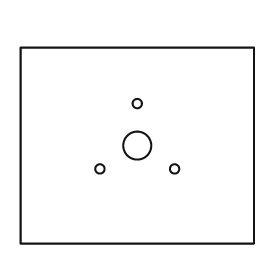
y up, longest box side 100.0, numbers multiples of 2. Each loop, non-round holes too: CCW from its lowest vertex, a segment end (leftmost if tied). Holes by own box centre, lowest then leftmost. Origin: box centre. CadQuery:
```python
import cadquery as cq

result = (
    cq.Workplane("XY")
    .moveTo(-50.0, -42.0)
    .lineTo(50.0, -42.0)
    .lineTo(50.0, 42.0)
    .lineTo(-50.0, 42.0)
    .close()
    .moveTo(-16.0, -10.0)
    .circle(2.0)
    .moveTo(16.0, -10.0)
    .circle(2.0)
    .moveTo(0.0, 0.0)
    .circle(6.0)
    .moveTo(0.0, 18.0)
    .circle(2.0)
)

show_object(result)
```